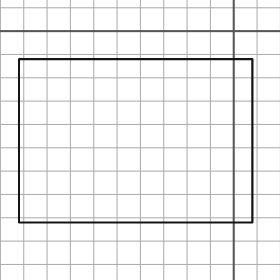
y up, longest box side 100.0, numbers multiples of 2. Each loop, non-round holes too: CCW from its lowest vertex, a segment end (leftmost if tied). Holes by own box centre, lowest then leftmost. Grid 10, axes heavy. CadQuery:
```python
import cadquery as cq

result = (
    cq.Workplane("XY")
    .moveTo(-92.0, -82.0)
    .lineTo(8.0, -82.0)
    .lineTo(8.0, -12.0)
    .lineTo(-92.0, -12.0)
    .close()
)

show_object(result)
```